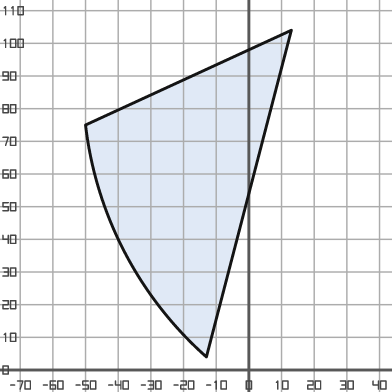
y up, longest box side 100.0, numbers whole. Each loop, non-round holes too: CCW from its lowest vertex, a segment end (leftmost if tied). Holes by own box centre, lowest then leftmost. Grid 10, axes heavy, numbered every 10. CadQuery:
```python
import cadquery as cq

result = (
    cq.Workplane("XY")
    .moveTo(-13.0, 4.0)
    .lineTo(13.0, 104.0)
    .lineTo(-50.0, 75.0)
    .threePointArc((-38.0, 36.0), (-13.0, 4.0))
    .close()
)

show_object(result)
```